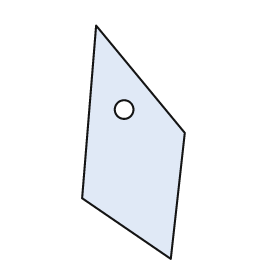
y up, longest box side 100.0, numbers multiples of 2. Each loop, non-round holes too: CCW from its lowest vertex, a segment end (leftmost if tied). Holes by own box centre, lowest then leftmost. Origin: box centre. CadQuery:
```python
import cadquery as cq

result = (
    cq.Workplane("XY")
    .moveTo(16.0, -50.0)
    .lineTo(22.0, 4.0)
    .lineTo(-16.0, 50.0)
    .lineTo(-22.0, -24.0)
    .close()
    .moveTo(-4.0, 14.0)
    .circle(4.0)
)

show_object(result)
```